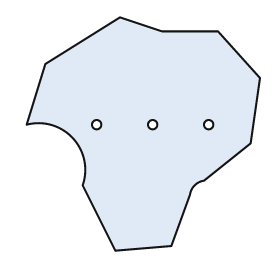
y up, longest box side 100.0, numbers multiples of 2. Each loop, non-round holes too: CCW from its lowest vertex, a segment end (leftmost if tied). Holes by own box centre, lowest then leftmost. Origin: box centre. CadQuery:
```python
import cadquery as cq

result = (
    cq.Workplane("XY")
    .moveTo(-12.0, -50.0)
    .lineTo(12.0, -48.0)
    .lineTo(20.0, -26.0)
    .threePointArc((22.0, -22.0), (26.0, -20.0))
    .lineTo(46.0, -4.0)
    .lineTo(50.0, 24.0)
    .lineTo(32.0, 44.0)
    .lineTo(8.0, 44.0)
    .lineTo(-10.0, 50.0)
    .lineTo(-42.0, 30.0)
    .lineTo(-50.0, 4.0)
    .threePointArc((-30.0, -2.0), (-26.0, -22.0))
    .close()
    .moveTo(-20.0, 4.0)
    .circle(2.0)
    .moveTo(4.0, 4.0)
    .circle(2.0)
    .moveTo(28.0, 4.0)
    .circle(2.0)
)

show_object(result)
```